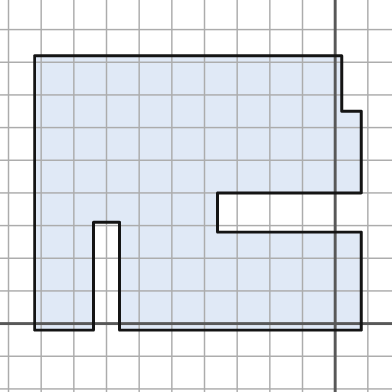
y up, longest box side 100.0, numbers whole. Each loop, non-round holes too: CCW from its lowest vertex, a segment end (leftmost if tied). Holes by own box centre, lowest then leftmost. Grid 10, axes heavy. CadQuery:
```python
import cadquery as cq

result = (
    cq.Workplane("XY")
    .moveTo(-92.0, -2.0)
    .lineTo(-74.0, -2.0)
    .lineTo(-74.0, 31.0)
    .lineTo(-66.0, 31.0)
    .lineTo(-66.0, -2.0)
    .lineTo(8.0, -2.0)
    .lineTo(8.0, 28.0)
    .lineTo(-36.0, 28.0)
    .lineTo(-36.0, 40.0)
    .lineTo(8.0, 40.0)
    .lineTo(8.0, 65.0)
    .lineTo(2.0, 65.0)
    .lineTo(2.0, 82.0)
    .lineTo(-92.0, 82.0)
    .close()
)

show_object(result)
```